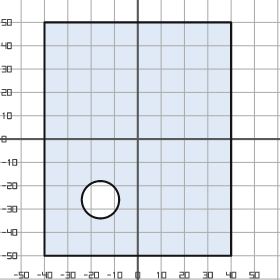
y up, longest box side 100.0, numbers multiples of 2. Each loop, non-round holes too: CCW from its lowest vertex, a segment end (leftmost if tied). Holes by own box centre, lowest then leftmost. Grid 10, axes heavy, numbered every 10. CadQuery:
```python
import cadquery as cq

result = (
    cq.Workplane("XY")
    .moveTo(-40.0, -50.0)
    .lineTo(40.0, -50.0)
    .lineTo(40.0, 50.0)
    .lineTo(-40.0, 50.0)
    .close()
    .moveTo(-16.0, -26.0)
    .circle(8.0)
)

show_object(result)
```